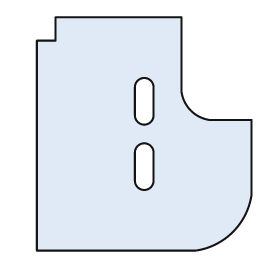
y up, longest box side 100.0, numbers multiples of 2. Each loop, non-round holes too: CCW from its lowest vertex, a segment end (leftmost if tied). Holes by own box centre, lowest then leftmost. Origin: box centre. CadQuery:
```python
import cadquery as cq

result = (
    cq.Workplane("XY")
    .moveTo(-46.0, -50.0)
    .lineTo(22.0, -50.0)
    .threePointArc((38.0, -42.0), (46.0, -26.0))
    .lineTo(46.0, 6.0)
    .lineTo(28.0, 6.0)
    .threePointArc((20.0, 10.0), (16.0, 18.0))
    .lineTo(16.0, 50.0)
    .lineTo(-38.0, 50.0)
    .lineTo(-38.0, 40.0)
    .lineTo(-46.0, 40.0)
    .close()
    .moveTo(-4.0, -20.0)
    .threePointArc((0.0, -24.0), (4.0, -20.0))
    .lineTo(4.0, -8.0)
    .threePointArc((0.0, -4.0), (-4.0, -8.0))
    .close()
    .moveTo(-4.0, 8.0)
    .threePointArc((0.0, 4.0), (4.0, 8.0))
    .lineTo(4.0, 20.0)
    .threePointArc((0.0, 24.0), (-4.0, 20.0))
    .close()
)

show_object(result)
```